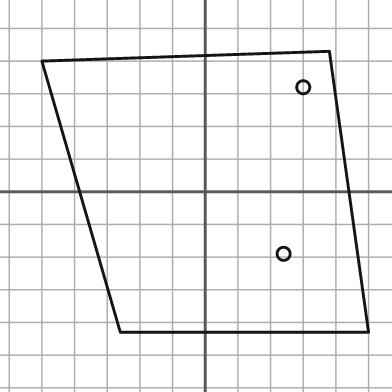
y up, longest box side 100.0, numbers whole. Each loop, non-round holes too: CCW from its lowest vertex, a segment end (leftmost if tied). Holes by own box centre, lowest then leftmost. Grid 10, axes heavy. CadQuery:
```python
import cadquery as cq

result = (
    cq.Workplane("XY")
    .moveTo(-26.0, -43.0)
    .lineTo(50.0, -43.0)
    .lineTo(38.0, 43.0)
    .lineTo(-50.0, 40.0)
    .close()
    .moveTo(24.0, -19.0)
    .circle(2.0)
    .moveTo(30.0, 32.0)
    .circle(2.0)
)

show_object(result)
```